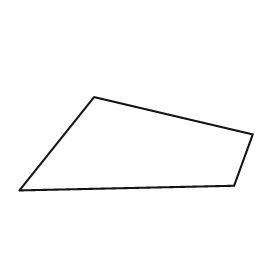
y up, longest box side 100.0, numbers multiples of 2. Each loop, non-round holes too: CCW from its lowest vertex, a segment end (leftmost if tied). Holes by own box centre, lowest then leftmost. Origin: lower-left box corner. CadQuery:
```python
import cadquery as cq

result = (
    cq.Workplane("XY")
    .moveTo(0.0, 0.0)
    .lineTo(92.0, 2.0)
    .lineTo(100.0, 24.0)
    .lineTo(32.0, 40.0)
    .close()
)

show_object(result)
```